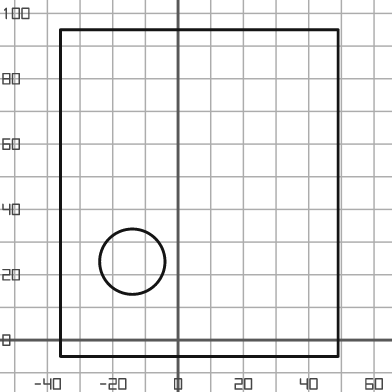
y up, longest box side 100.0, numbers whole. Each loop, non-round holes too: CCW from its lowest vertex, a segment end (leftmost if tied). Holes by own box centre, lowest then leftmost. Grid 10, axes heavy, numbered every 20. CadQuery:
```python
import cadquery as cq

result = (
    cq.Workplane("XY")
    .moveTo(-36.0, -5.0)
    .lineTo(49.0, -5.0)
    .lineTo(49.0, 95.0)
    .lineTo(-36.0, 95.0)
    .close()
    .moveTo(-14.0, 24.0)
    .circle(10.0)
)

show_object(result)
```